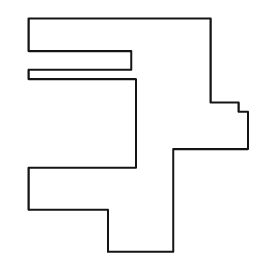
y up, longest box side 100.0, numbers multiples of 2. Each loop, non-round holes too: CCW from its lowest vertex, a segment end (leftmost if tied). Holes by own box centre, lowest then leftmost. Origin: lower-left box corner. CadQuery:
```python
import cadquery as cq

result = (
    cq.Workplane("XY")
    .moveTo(34.0, 0.0)
    .lineTo(62.0, 0.0)
    .lineTo(62.0, 44.0)
    .lineTo(94.0, 44.0)
    .lineTo(94.0, 60.0)
    .lineTo(90.0, 60.0)
    .lineTo(90.0, 64.0)
    .lineTo(78.0, 64.0)
    .lineTo(78.0, 100.0)
    .lineTo(0.0, 100.0)
    .lineTo(0.0, 86.0)
    .lineTo(44.0, 86.0)
    .lineTo(44.0, 78.0)
    .lineTo(0.0, 78.0)
    .lineTo(0.0, 74.0)
    .lineTo(46.0, 74.0)
    .lineTo(46.0, 36.0)
    .lineTo(0.0, 36.0)
    .lineTo(0.0, 18.0)
    .lineTo(34.0, 18.0)
    .close()
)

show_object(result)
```